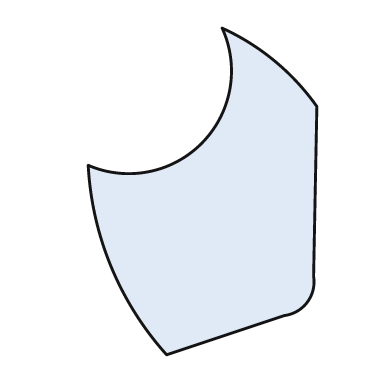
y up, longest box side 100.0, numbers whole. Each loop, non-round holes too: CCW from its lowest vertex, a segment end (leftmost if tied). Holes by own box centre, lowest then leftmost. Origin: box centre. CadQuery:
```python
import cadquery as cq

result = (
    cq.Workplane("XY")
    .moveTo(-11.0, -50.0)
    .lineTo(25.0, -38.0)
    .threePointArc((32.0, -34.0), (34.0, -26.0))
    .lineTo(35.0, 26.0)
    .threePointArc((22.0, 40.0), (6.0, 50.0))
    .threePointArc((0.0, 15.0), (-35.0, 8.0))
    .threePointArc((-28.0, -23.0), (-11.0, -50.0))
    .close()
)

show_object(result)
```